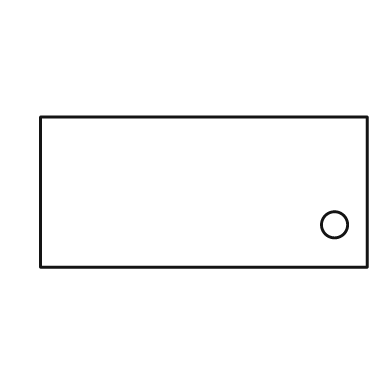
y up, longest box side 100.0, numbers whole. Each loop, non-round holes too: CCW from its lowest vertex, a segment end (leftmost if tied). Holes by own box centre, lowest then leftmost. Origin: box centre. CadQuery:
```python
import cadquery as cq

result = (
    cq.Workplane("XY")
    .moveTo(-50.0, -23.0)
    .lineTo(50.0, -23.0)
    .lineTo(50.0, 23.0)
    .lineTo(-50.0, 23.0)
    .close()
    .moveTo(40.0, -10.0)
    .circle(4.0)
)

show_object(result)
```